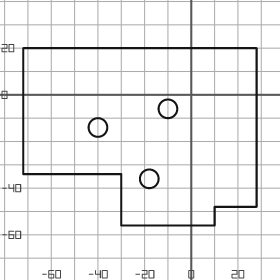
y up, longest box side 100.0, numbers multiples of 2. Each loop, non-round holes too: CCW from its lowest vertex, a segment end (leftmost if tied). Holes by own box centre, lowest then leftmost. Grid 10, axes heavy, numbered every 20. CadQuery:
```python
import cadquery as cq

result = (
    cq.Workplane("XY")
    .moveTo(-30.0, -56.0)
    .lineTo(10.0, -56.0)
    .lineTo(10.0, -48.0)
    .lineTo(28.0, -48.0)
    .lineTo(28.0, 20.0)
    .lineTo(-72.0, 20.0)
    .lineTo(-72.0, -34.0)
    .lineTo(-30.0, -34.0)
    .close()
    .moveTo(-18.0, -36.0)
    .circle(4.0)
    .moveTo(-40.0, -14.0)
    .circle(4.0)
    .moveTo(-10.0, -6.0)
    .circle(4.0)
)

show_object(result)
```